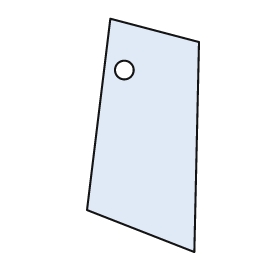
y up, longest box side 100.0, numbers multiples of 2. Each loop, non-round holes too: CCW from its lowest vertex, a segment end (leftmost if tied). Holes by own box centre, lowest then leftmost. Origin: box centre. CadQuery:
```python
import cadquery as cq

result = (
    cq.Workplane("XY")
    .moveTo(22.0, -50.0)
    .lineTo(24.0, 40.0)
    .lineTo(-14.0, 50.0)
    .lineTo(-24.0, -32.0)
    .close()
    .moveTo(-8.0, 28.0)
    .circle(4.0)
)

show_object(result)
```